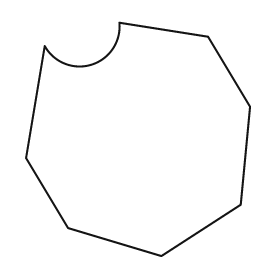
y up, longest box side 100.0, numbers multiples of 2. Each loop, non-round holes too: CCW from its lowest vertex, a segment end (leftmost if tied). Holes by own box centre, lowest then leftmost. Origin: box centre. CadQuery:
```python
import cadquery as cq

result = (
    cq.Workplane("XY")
    .moveTo(10.0, -50.0)
    .lineTo(44.0, -28.0)
    .lineTo(48.0, 14.0)
    .lineTo(30.0, 44.0)
    .lineTo(-8.0, 50.0)
    .threePointArc((-20.0, 32.0), (-40.0, 40.0))
    .lineTo(-48.0, -8.0)
    .lineTo(-30.0, -38.0)
    .close()
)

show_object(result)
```